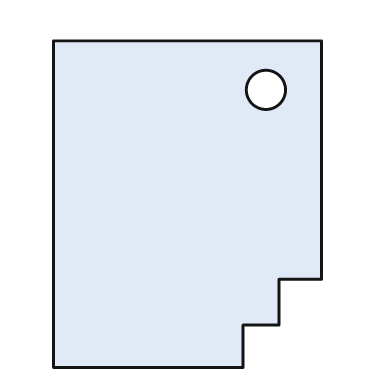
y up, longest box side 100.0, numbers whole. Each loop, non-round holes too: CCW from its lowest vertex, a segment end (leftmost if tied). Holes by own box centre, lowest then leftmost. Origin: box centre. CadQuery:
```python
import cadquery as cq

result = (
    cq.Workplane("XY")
    .moveTo(-41.0, -50.0)
    .lineTo(17.0, -50.0)
    .lineTo(17.0, -37.0)
    .lineTo(28.0, -37.0)
    .lineTo(28.0, -23.0)
    .lineTo(41.0, -23.0)
    .lineTo(41.0, 50.0)
    .lineTo(-41.0, 50.0)
    .close()
    .moveTo(24.0, 35.0)
    .circle(6.0)
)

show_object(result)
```